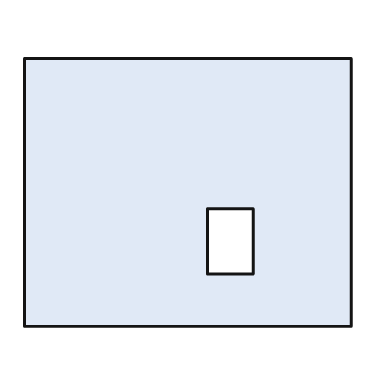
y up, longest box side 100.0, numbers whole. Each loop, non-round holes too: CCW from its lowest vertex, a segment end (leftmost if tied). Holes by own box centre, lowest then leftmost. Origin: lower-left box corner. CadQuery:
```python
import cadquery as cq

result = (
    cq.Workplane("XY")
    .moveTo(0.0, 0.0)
    .lineTo(100.0, 0.0)
    .lineTo(100.0, 82.0)
    .lineTo(0.0, 82.0)
    .close()
    .moveTo(56.0, 16.0)
    .lineTo(70.0, 16.0)
    .lineTo(70.0, 36.0)
    .lineTo(56.0, 36.0)
    .close()
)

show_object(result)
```